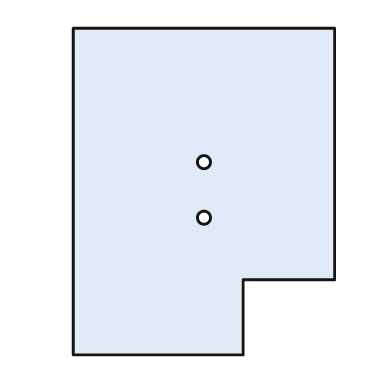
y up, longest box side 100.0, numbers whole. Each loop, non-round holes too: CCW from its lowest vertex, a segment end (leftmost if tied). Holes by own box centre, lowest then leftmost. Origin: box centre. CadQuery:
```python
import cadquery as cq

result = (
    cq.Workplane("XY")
    .moveTo(-40.0, -50.0)
    .lineTo(12.0, -50.0)
    .lineTo(12.0, -27.0)
    .lineTo(40.0, -27.0)
    .lineTo(40.0, 50.0)
    .lineTo(-40.0, 50.0)
    .close()
    .moveTo(0.0, -8.0)
    .circle(2.0)
    .moveTo(0.0, 9.0)
    .circle(2.0)
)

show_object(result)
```